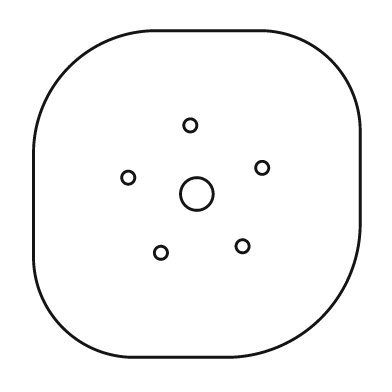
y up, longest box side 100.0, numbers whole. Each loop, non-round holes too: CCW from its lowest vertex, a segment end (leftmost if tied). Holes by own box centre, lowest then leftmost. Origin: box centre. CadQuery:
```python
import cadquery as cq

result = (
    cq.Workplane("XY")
    .moveTo(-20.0, -50.0)
    .lineTo(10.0, -50.0)
    .threePointArc((38.0, -38.0), (50.0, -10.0))
    .lineTo(50.0, 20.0)
    .threePointArc((41.0, 41.0), (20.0, 50.0))
    .lineTo(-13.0, 50.0)
    .threePointArc((-39.0, 39.0), (-50.0, 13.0))
    .lineTo(-50.0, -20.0)
    .threePointArc((-41.0, -41.0), (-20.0, -50.0))
    .close()
    .moveTo(-11.0, -18.0)
    .circle(2.0)
    .moveTo(14.0, -16.0)
    .circle(2.0)
    .moveTo(0.0, 0.0)
    .circle(5.0)
    .moveTo(-21.0, 5.0)
    .circle(2.0)
    .moveTo(20.0, 8.0)
    .circle(2.0)
    .moveTo(-2.0, 21.0)
    .circle(2.0)
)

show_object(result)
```